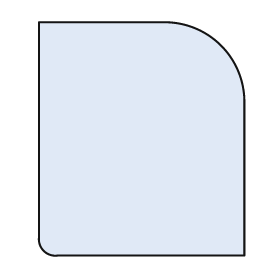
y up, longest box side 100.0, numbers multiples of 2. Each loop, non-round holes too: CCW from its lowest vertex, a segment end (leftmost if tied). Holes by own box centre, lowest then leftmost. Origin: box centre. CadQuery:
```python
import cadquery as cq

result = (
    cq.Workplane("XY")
    .moveTo(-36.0, -50.0)
    .lineTo(44.0, -50.0)
    .lineTo(44.0, 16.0)
    .threePointArc((34.0, 40.0), (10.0, 50.0))
    .lineTo(-44.0, 50.0)
    .lineTo(-44.0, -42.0)
    .threePointArc((-42.0, -48.0), (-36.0, -50.0))
    .close()
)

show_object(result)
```